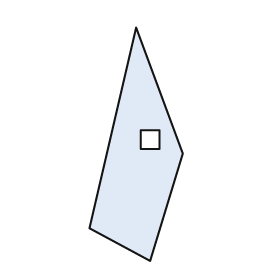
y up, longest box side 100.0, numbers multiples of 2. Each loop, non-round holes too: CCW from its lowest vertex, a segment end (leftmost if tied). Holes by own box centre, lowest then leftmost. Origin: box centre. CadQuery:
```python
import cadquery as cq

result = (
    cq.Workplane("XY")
    .moveTo(6.0, -50.0)
    .lineTo(20.0, -4.0)
    .lineTo(0.0, 50.0)
    .lineTo(-20.0, -36.0)
    .close()
    .moveTo(2.0, -2.0)
    .lineTo(10.0, -2.0)
    .lineTo(10.0, 6.0)
    .lineTo(2.0, 6.0)
    .close()
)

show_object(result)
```